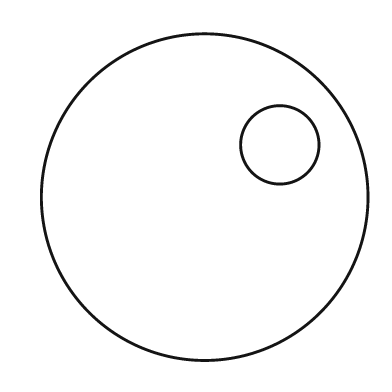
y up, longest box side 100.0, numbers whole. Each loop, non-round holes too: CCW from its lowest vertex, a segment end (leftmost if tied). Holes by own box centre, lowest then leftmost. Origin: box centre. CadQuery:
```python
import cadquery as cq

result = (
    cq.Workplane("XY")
    .moveTo(0.0, 0.0)
    .circle(50.0)
    .moveTo(23.0, 16.0)
    .circle(12.0)
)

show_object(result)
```